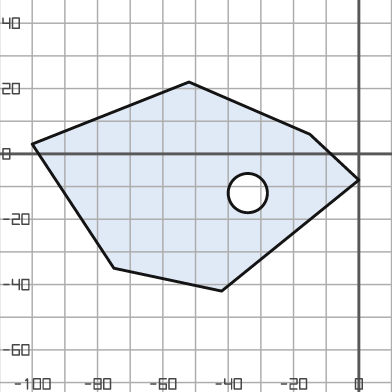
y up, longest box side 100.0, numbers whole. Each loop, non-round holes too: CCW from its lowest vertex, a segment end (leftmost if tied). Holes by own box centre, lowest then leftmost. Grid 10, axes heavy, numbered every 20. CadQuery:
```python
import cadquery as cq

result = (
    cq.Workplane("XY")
    .moveTo(-42.0, -42.0)
    .lineTo(0.0, -8.0)
    .lineTo(-15.0, 6.0)
    .lineTo(-52.0, 22.0)
    .lineTo(-100.0, 3.0)
    .lineTo(-75.0, -35.0)
    .close()
    .moveTo(-34.0, -12.0)
    .circle(6.0)
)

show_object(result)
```